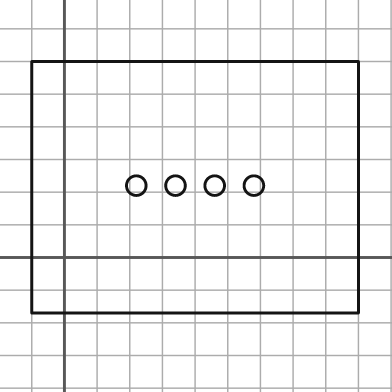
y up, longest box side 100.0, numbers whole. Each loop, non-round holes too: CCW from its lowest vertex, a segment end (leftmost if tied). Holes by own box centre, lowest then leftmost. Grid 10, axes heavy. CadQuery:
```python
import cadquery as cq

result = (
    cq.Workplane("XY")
    .moveTo(-10.0, -17.0)
    .lineTo(90.0, -17.0)
    .lineTo(90.0, 60.0)
    .lineTo(-10.0, 60.0)
    .close()
    .moveTo(22.0, 22.0)
    .circle(3.0)
    .moveTo(34.0, 22.0)
    .circle(3.0)
    .moveTo(46.0, 22.0)
    .circle(3.0)
    .moveTo(58.0, 22.0)
    .circle(3.0)
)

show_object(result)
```